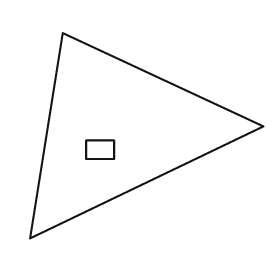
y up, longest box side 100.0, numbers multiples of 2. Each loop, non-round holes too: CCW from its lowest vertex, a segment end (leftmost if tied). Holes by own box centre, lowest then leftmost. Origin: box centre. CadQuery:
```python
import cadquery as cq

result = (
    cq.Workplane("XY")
    .moveTo(-50.0, -44.0)
    .lineTo(50.0, 4.0)
    .lineTo(-36.0, 44.0)
    .close()
    .moveTo(-26.0, -10.0)
    .lineTo(-14.0, -10.0)
    .lineTo(-14.0, -2.0)
    .lineTo(-26.0, -2.0)
    .close()
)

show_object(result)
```